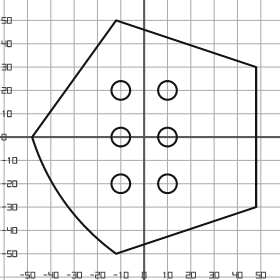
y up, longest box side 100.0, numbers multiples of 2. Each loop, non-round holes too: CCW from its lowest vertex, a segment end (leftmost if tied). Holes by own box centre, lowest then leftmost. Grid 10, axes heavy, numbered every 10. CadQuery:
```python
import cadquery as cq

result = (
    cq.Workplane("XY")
    .moveTo(-12.0, -50.0)
    .lineTo(48.0, -30.0)
    .lineTo(48.0, 30.0)
    .lineTo(-12.0, 50.0)
    .lineTo(-48.0, 0.0)
    .threePointArc((-34.0, -28.0), (-12.0, -50.0))
    .close()
    .moveTo(-10.0, -20.0)
    .circle(4.0)
    .moveTo(10.0, -20.0)
    .circle(4.0)
    .moveTo(-10.0, 0.0)
    .circle(4.0)
    .moveTo(10.0, 0.0)
    .circle(4.0)
    .moveTo(-10.0, 20.0)
    .circle(4.0)
    .moveTo(10.0, 20.0)
    .circle(4.0)
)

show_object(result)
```